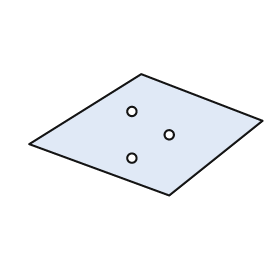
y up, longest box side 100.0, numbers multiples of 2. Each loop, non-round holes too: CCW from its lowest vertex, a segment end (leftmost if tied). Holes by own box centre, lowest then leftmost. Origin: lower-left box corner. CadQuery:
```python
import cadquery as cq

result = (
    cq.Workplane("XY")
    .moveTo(60.0, 0.0)
    .lineTo(100.0, 32.0)
    .lineTo(48.0, 52.0)
    .lineTo(0.0, 22.0)
    .close()
    .moveTo(44.0, 16.0)
    .circle(2.0)
    .moveTo(60.0, 26.0)
    .circle(2.0)
    .moveTo(44.0, 36.0)
    .circle(2.0)
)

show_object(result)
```